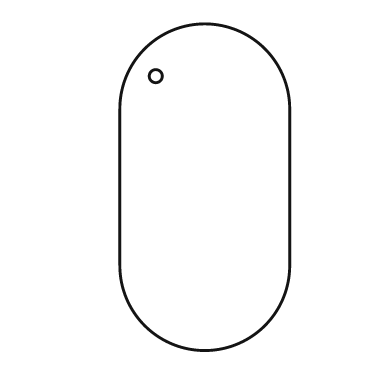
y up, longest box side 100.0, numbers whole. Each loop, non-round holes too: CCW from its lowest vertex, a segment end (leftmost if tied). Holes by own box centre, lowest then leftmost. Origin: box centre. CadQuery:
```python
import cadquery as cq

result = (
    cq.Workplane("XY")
    .moveTo(-26.0, -24.0)
    .threePointArc((0.0, -50.0), (26.0, -24.0))
    .lineTo(26.0, 24.0)
    .threePointArc((0.0, 50.0), (-26.0, 24.0))
    .close()
    .moveTo(-15.0, 34.0)
    .circle(2.0)
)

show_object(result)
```